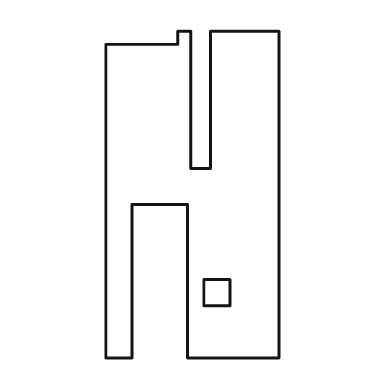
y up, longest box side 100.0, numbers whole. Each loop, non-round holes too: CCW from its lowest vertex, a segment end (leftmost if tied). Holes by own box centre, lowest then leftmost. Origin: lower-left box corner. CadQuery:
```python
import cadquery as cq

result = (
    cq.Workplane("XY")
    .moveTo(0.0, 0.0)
    .lineTo(8.0, 0.0)
    .lineTo(8.0, 47.0)
    .lineTo(25.0, 47.0)
    .lineTo(25.0, 0.0)
    .lineTo(53.0, 0.0)
    .lineTo(53.0, 100.0)
    .lineTo(32.0, 100.0)
    .lineTo(32.0, 58.0)
    .lineTo(26.0, 58.0)
    .lineTo(26.0, 100.0)
    .lineTo(22.0, 100.0)
    .lineTo(22.0, 96.0)
    .lineTo(0.0, 96.0)
    .close()
    .moveTo(30.0, 16.0)
    .lineTo(38.0, 16.0)
    .lineTo(38.0, 24.0)
    .lineTo(30.0, 24.0)
    .close()
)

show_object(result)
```